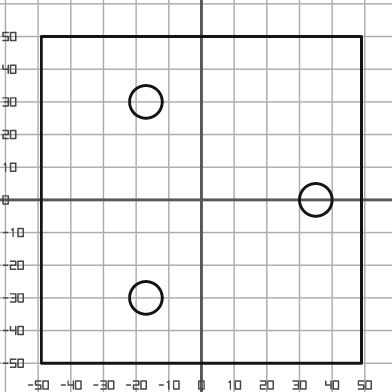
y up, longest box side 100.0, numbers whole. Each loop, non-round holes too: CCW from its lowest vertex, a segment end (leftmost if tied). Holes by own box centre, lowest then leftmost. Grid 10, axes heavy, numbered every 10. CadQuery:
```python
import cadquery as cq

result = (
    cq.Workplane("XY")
    .moveTo(-49.0, -50.0)
    .lineTo(49.0, -50.0)
    .lineTo(49.0, 50.0)
    .lineTo(-49.0, 50.0)
    .close()
    .moveTo(-17.0, -30.0)
    .circle(5.0)
    .moveTo(35.0, 0.0)
    .circle(5.0)
    .moveTo(-17.0, 30.0)
    .circle(5.0)
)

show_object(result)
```